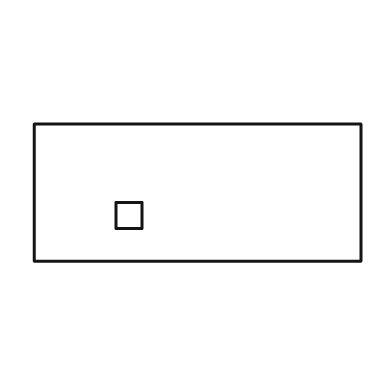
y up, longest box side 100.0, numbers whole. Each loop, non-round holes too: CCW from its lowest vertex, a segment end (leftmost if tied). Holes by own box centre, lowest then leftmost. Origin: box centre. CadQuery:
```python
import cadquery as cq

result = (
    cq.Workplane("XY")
    .moveTo(-50.0, -21.0)
    .lineTo(50.0, -21.0)
    .lineTo(50.0, 21.0)
    .lineTo(-50.0, 21.0)
    .close()
    .moveTo(-25.0, -11.0)
    .lineTo(-17.0, -11.0)
    .lineTo(-17.0, -3.0)
    .lineTo(-25.0, -3.0)
    .close()
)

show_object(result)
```